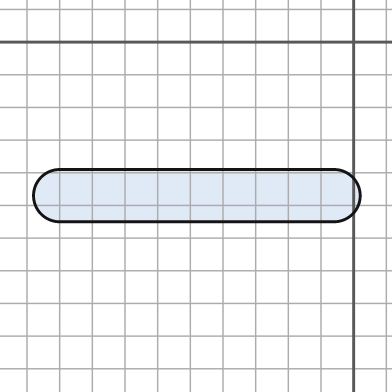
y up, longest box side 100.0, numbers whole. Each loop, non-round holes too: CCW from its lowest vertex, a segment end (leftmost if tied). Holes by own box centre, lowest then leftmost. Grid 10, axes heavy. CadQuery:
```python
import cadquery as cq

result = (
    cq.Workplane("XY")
    .moveTo(-90.0, -55.0)
    .lineTo(-6.0, -55.0)
    .threePointArc((2.0, -47.0), (-6.0, -39.0))
    .lineTo(-90.0, -39.0)
    .threePointArc((-98.0, -47.0), (-90.0, -55.0))
    .close()
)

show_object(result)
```